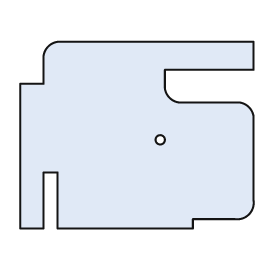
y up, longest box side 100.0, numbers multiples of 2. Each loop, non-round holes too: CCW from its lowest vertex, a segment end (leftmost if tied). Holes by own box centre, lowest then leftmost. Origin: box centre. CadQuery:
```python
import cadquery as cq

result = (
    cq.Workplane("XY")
    .moveTo(-50.0, -40.0)
    .lineTo(-40.0, -40.0)
    .lineTo(-40.0, -16.0)
    .lineTo(-34.0, -16.0)
    .lineTo(-34.0, -40.0)
    .lineTo(24.0, -40.0)
    .lineTo(24.0, -36.0)
    .lineTo(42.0, -36.0)
    .threePointArc((48.0, -34.0), (50.0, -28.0))
    .lineTo(50.0, 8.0)
    .threePointArc((48.0, 12.0), (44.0, 14.0))
    .lineTo(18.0, 14.0)
    .threePointArc((14.0, 16.0), (12.0, 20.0))
    .lineTo(12.0, 28.0)
    .lineTo(50.0, 28.0)
    .lineTo(50.0, 40.0)
    .lineTo(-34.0, 40.0)
    .threePointArc((-38.0, 38.0), (-40.0, 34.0))
    .lineTo(-40.0, 22.0)
    .lineTo(-50.0, 22.0)
    .close()
    .moveTo(10.0, -2.0)
    .circle(2.0)
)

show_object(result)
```